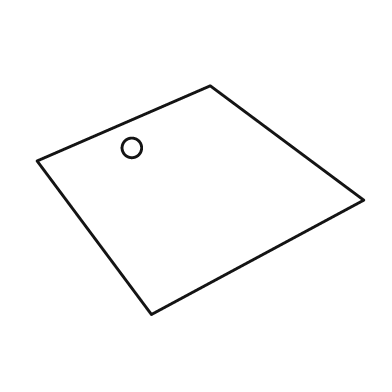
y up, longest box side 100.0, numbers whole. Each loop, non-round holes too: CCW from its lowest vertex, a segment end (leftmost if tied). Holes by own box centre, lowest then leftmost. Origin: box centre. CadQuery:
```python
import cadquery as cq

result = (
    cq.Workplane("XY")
    .moveTo(-15.0, -35.0)
    .lineTo(50.0, 0.0)
    .lineTo(3.0, 35.0)
    .lineTo(-50.0, 12.0)
    .close()
    .moveTo(-21.0, 16.0)
    .circle(3.0)
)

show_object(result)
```